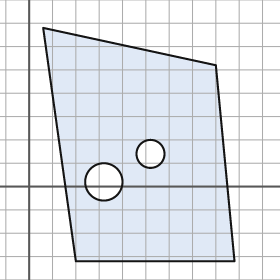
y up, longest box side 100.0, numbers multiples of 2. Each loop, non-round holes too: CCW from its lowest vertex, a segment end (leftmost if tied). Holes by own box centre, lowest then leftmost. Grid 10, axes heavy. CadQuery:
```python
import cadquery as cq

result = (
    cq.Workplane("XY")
    .moveTo(20.0, -32.0)
    .lineTo(88.0, -32.0)
    .lineTo(80.0, 52.0)
    .lineTo(6.0, 68.0)
    .close()
    .moveTo(32.0, 2.0)
    .circle(8.0)
    .moveTo(52.0, 14.0)
    .circle(6.0)
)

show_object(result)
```